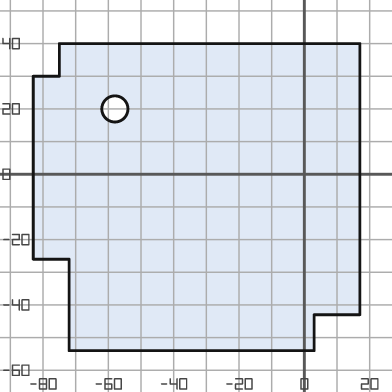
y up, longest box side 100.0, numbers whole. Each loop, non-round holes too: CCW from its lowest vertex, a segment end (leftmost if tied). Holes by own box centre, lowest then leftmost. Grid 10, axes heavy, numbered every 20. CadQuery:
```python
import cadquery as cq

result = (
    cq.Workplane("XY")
    .moveTo(-72.0, -54.0)
    .lineTo(3.0, -54.0)
    .lineTo(3.0, -43.0)
    .lineTo(17.0, -43.0)
    .lineTo(17.0, 40.0)
    .lineTo(-75.0, 40.0)
    .lineTo(-75.0, 30.0)
    .lineTo(-83.0, 30.0)
    .lineTo(-83.0, -26.0)
    .lineTo(-72.0, -26.0)
    .close()
    .moveTo(-58.0, 20.0)
    .circle(4.0)
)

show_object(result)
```